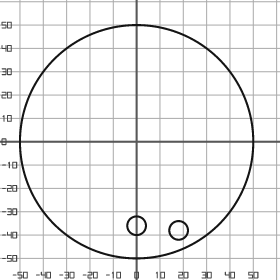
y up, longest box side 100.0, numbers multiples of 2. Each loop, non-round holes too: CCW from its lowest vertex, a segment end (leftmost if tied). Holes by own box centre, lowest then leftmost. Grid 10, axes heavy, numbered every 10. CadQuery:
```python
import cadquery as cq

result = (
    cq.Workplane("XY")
    .moveTo(0.0, 0.0)
    .circle(50.0)
    .moveTo(18.0, -38.0)
    .circle(4.0)
    .moveTo(0.0, -36.0)
    .circle(4.0)
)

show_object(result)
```